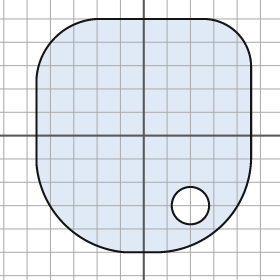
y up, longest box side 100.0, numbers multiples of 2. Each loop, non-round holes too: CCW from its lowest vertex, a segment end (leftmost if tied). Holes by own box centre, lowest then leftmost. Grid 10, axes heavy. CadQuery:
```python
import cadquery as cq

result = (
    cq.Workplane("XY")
    .moveTo(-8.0, -50.0)
    .lineTo(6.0, -50.0)
    .threePointArc((34.0, -38.0), (46.0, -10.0))
    .lineTo(46.0, 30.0)
    .threePointArc((40.0, 44.0), (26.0, 50.0))
    .lineTo(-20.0, 50.0)
    .threePointArc((-38.0, 42.0), (-46.0, 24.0))
    .lineTo(-46.0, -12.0)
    .threePointArc((-34.0, -38.0), (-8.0, -50.0))
    .close()
    .moveTo(20.0, -30.0)
    .circle(8.0)
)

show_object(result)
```